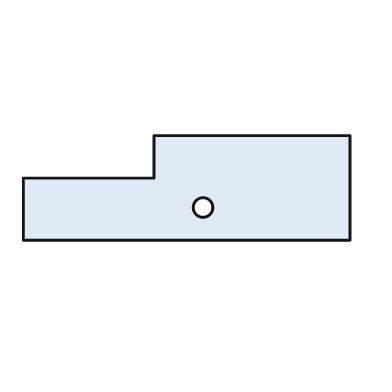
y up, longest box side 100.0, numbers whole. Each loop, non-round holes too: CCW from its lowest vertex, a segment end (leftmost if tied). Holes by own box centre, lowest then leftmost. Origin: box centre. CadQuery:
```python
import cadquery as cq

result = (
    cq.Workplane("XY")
    .moveTo(-50.0, -16.0)
    .lineTo(50.0, -16.0)
    .lineTo(50.0, 16.0)
    .lineTo(-10.0, 16.0)
    .lineTo(-10.0, 3.0)
    .lineTo(-50.0, 3.0)
    .close()
    .moveTo(5.0, -6.0)
    .circle(3.0)
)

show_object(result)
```